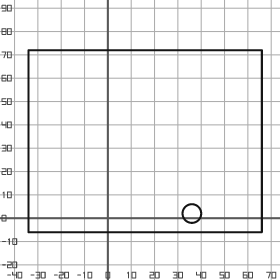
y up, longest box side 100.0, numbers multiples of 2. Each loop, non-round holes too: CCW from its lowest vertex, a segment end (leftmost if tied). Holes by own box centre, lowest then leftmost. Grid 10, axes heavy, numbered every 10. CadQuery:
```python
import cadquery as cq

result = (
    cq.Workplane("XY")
    .moveTo(-34.0, -6.0)
    .lineTo(66.0, -6.0)
    .lineTo(66.0, 72.0)
    .lineTo(-34.0, 72.0)
    .close()
    .moveTo(36.0, 2.0)
    .circle(4.0)
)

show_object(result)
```